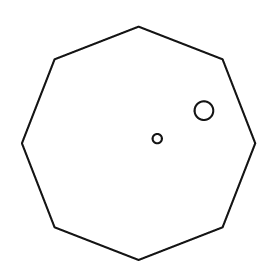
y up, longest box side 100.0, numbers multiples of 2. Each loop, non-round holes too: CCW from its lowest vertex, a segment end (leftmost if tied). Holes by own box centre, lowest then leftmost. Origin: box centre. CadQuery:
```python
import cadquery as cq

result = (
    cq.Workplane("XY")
    .moveTo(0.0, -50.0)
    .lineTo(36.0, -36.0)
    .lineTo(50.0, 0.0)
    .lineTo(36.0, 36.0)
    .lineTo(0.0, 50.0)
    .lineTo(-36.0, 36.0)
    .lineTo(-50.0, 0.0)
    .lineTo(-36.0, -36.0)
    .close()
    .moveTo(8.0, 2.0)
    .circle(2.0)
    .moveTo(28.0, 14.0)
    .circle(4.0)
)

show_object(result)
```